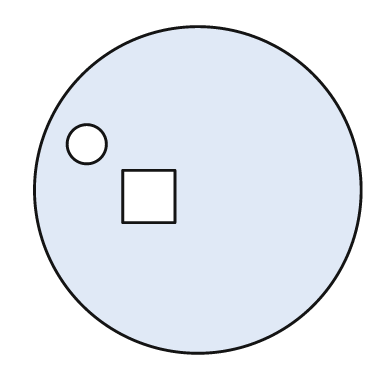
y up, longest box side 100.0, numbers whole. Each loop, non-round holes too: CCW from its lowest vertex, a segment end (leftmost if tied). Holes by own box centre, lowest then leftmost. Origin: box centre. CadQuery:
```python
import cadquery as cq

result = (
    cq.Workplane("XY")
    .moveTo(0.0, 0.0)
    .circle(50.0)
    .moveTo(-23.0, -10.0)
    .lineTo(-7.0, -10.0)
    .lineTo(-7.0, 6.0)
    .lineTo(-23.0, 6.0)
    .close()
    .moveTo(-34.0, 14.0)
    .circle(6.0)
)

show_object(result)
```